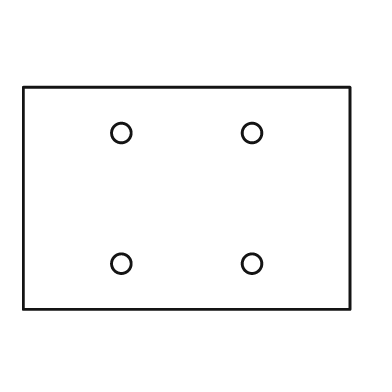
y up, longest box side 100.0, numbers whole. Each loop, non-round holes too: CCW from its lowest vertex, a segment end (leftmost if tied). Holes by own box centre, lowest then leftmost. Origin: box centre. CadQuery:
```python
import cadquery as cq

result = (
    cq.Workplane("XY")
    .moveTo(-50.0, -34.0)
    .lineTo(50.0, -34.0)
    .lineTo(50.0, 34.0)
    .lineTo(-50.0, 34.0)
    .close()
    .moveTo(-20.0, -20.0)
    .circle(3.0)
    .moveTo(20.0, -20.0)
    .circle(3.0)
    .moveTo(-20.0, 20.0)
    .circle(3.0)
    .moveTo(20.0, 20.0)
    .circle(3.0)
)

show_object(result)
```